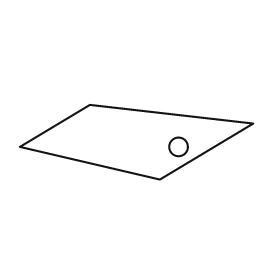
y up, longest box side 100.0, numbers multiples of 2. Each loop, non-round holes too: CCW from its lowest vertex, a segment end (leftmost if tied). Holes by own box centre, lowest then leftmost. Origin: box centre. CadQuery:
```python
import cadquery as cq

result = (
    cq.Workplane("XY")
    .moveTo(10.0, -16.0)
    .lineTo(50.0, 8.0)
    .lineTo(-20.0, 16.0)
    .lineTo(-50.0, -2.0)
    .close()
    .moveTo(18.0, -2.0)
    .circle(4.0)
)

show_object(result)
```